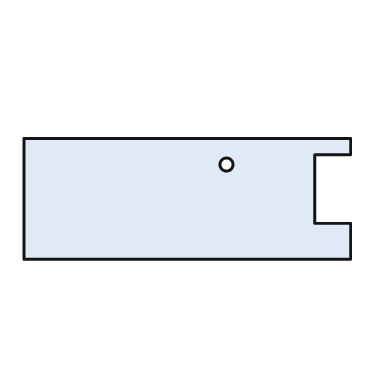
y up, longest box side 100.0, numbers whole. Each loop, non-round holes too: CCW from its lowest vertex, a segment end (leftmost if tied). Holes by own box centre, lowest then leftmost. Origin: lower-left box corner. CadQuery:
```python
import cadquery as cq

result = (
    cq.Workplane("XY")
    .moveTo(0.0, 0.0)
    .lineTo(100.0, 0.0)
    .lineTo(100.0, 11.0)
    .lineTo(89.0, 11.0)
    .lineTo(89.0, 32.0)
    .lineTo(100.0, 32.0)
    .lineTo(100.0, 37.0)
    .lineTo(0.0, 37.0)
    .close()
    .moveTo(62.0, 29.0)
    .circle(2.0)
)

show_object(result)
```